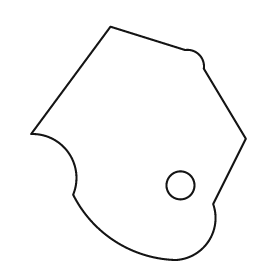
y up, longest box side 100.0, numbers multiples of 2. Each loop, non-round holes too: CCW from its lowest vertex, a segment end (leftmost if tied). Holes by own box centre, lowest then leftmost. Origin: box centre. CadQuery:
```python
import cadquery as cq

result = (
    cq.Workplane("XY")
    .moveTo(16.0, -50.0)
    .threePointArc((30.0, -42.0), (32.0, -26.0))
    .lineTo(46.0, 2.0)
    .lineTo(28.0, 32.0)
    .threePointArc((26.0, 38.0), (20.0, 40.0))
    .lineTo(-12.0, 50.0)
    .lineTo(-46.0, 4.0)
    .threePointArc((-30.0, -4.0), (-28.0, -22.0))
    .threePointArc((-10.0, -42.0), (16.0, -50.0))
    .close()
    .moveTo(18.0, -18.0)
    .circle(6.0)
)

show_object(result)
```